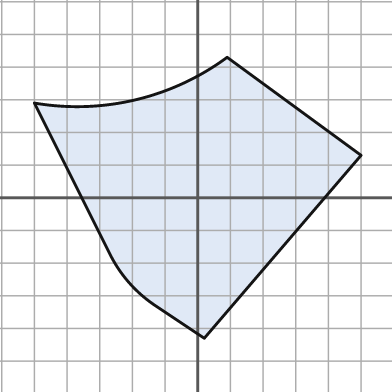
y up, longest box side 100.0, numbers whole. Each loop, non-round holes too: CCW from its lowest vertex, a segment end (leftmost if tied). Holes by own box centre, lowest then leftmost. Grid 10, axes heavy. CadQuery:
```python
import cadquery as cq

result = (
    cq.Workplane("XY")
    .moveTo(2.0, -43.0)
    .lineTo(50.0, 13.0)
    .lineTo(9.0, 43.0)
    .threePointArc((-19.0, 30.0), (-50.0, 29.0))
    .lineTo(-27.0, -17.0)
    .threePointArc((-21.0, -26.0), (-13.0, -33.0))
    .close()
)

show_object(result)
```